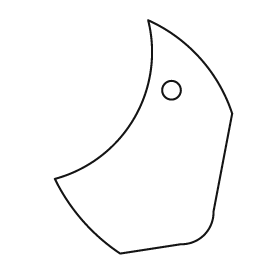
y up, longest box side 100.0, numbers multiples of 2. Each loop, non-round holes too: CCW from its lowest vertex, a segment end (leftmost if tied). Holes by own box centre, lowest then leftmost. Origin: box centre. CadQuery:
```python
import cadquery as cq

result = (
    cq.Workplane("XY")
    .moveTo(-10.0, -50.0)
    .lineTo(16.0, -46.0)
    .threePointArc((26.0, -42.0), (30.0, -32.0))
    .lineTo(38.0, 10.0)
    .threePointArc((24.0, 34.0), (2.0, 50.0))
    .threePointArc((-4.0, 8.0), (-38.0, -18.0))
    .threePointArc((-26.0, -36.0), (-10.0, -50.0))
    .close()
    .moveTo(12.0, 20.0)
    .circle(4.0)
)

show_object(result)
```